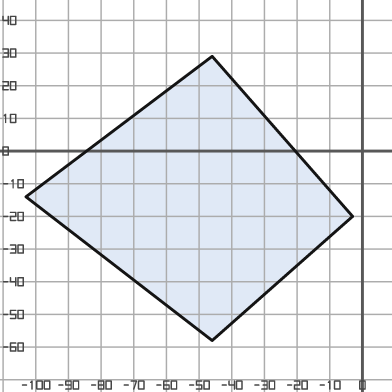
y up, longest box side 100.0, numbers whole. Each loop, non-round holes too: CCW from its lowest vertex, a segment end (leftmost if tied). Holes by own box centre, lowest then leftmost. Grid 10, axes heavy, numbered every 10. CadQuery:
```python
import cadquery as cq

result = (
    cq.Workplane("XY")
    .moveTo(-46.0, -58.0)
    .lineTo(-3.0, -20.0)
    .lineTo(-46.0, 29.0)
    .lineTo(-103.0, -14.0)
    .close()
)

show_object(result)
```